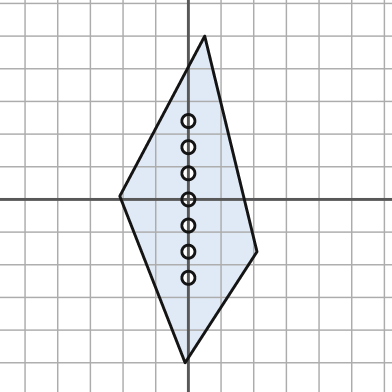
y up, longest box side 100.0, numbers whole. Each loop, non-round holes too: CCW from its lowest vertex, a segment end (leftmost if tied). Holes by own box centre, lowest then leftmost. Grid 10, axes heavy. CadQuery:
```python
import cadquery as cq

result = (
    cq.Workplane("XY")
    .moveTo(-1.0, -50.0)
    .lineTo(21.0, -16.0)
    .lineTo(5.0, 50.0)
    .lineTo(-21.0, 1.0)
    .close()
    .moveTo(0.0, -24.0)
    .circle(2.0)
    .moveTo(0.0, -16.0)
    .circle(2.0)
    .moveTo(0.0, -8.0)
    .circle(2.0)
    .moveTo(0.0, 0.0)
    .circle(2.0)
    .moveTo(0.0, 8.0)
    .circle(2.0)
    .moveTo(0.0, 16.0)
    .circle(2.0)
    .moveTo(0.0, 24.0)
    .circle(2.0)
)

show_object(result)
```